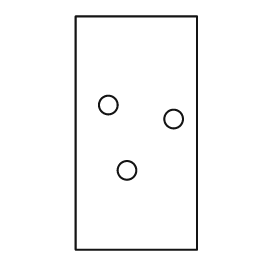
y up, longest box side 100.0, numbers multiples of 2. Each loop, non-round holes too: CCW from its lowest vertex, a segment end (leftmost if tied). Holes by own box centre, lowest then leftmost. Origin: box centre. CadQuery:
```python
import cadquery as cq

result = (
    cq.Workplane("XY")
    .moveTo(-26.0, -50.0)
    .lineTo(26.0, -50.0)
    .lineTo(26.0, 50.0)
    .lineTo(-26.0, 50.0)
    .close()
    .moveTo(-4.0, -16.0)
    .circle(4.0)
    .moveTo(16.0, 6.0)
    .circle(4.0)
    .moveTo(-12.0, 12.0)
    .circle(4.0)
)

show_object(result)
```